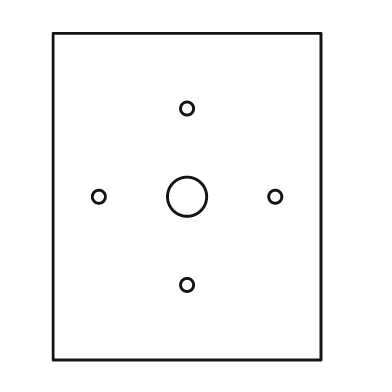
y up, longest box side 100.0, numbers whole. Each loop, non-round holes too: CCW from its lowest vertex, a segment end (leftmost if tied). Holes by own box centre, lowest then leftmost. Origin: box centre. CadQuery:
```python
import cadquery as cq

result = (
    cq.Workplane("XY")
    .moveTo(-41.0, -50.0)
    .lineTo(41.0, -50.0)
    .lineTo(41.0, 50.0)
    .lineTo(-41.0, 50.0)
    .close()
    .moveTo(0.0, -27.0)
    .circle(2.0)
    .moveTo(-27.0, 0.0)
    .circle(2.0)
    .moveTo(0.0, 0.0)
    .circle(6.0)
    .moveTo(27.0, 0.0)
    .circle(2.0)
    .moveTo(0.0, 27.0)
    .circle(2.0)
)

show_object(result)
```